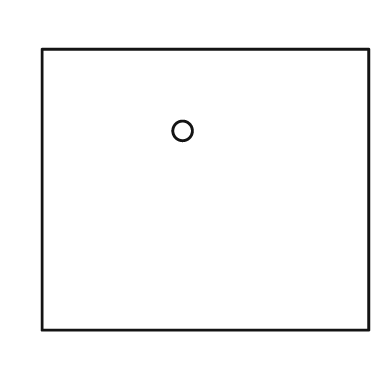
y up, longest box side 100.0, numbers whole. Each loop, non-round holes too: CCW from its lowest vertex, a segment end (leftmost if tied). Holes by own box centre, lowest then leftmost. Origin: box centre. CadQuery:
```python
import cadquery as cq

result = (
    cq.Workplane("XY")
    .moveTo(-50.0, -43.0)
    .lineTo(50.0, -43.0)
    .lineTo(50.0, 43.0)
    .lineTo(-50.0, 43.0)
    .close()
    .moveTo(-7.0, 18.0)
    .circle(3.0)
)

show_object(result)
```